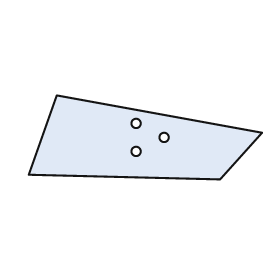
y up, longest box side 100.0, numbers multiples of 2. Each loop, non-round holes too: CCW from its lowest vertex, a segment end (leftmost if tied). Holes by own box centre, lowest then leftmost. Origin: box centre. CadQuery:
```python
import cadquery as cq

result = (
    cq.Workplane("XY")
    .moveTo(32.0, -18.0)
    .lineTo(50.0, 2.0)
    .lineTo(-38.0, 18.0)
    .lineTo(-50.0, -16.0)
    .close()
    .moveTo(-4.0, -6.0)
    .circle(2.0)
    .moveTo(8.0, 0.0)
    .circle(2.0)
    .moveTo(-4.0, 6.0)
    .circle(2.0)
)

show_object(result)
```